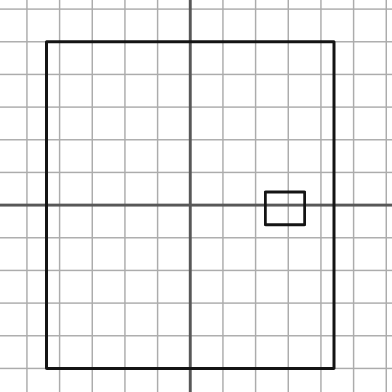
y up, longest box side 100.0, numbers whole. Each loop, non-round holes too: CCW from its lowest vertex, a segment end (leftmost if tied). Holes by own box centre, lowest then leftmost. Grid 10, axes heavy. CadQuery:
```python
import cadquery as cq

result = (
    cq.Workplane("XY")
    .moveTo(-44.0, -50.0)
    .lineTo(44.0, -50.0)
    .lineTo(44.0, 50.0)
    .lineTo(-44.0, 50.0)
    .close()
    .moveTo(23.0, -6.0)
    .lineTo(35.0, -6.0)
    .lineTo(35.0, 4.0)
    .lineTo(23.0, 4.0)
    .close()
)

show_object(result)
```